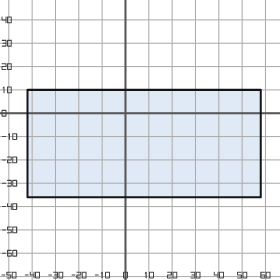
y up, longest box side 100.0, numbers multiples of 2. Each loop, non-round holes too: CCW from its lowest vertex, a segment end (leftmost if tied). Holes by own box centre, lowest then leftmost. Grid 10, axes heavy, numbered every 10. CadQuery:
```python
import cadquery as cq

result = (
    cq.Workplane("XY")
    .moveTo(-42.0, -36.0)
    .lineTo(58.0, -36.0)
    .lineTo(58.0, 10.0)
    .lineTo(-42.0, 10.0)
    .close()
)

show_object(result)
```